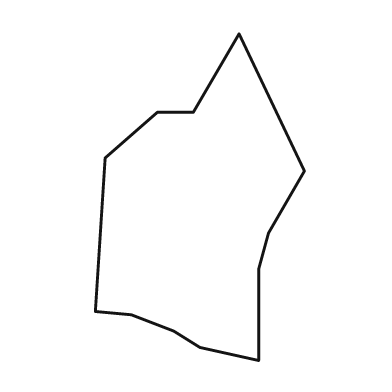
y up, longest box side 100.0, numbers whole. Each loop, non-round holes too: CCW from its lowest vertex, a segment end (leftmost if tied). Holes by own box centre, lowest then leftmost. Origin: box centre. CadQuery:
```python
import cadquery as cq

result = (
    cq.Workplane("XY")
    .moveTo(18.0, -50.0)
    .lineTo(18.0, -22.0)
    .lineTo(21.0, -11.0)
    .lineTo(32.0, 8.0)
    .lineTo(12.0, 50.0)
    .lineTo(-2.0, 26.0)
    .lineTo(-13.0, 26.0)
    .lineTo(-29.0, 12.0)
    .lineTo(-32.0, -35.0)
    .lineTo(-21.0, -36.0)
    .lineTo(-8.0, -41.0)
    .lineTo(0.0, -46.0)
    .close()
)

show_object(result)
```